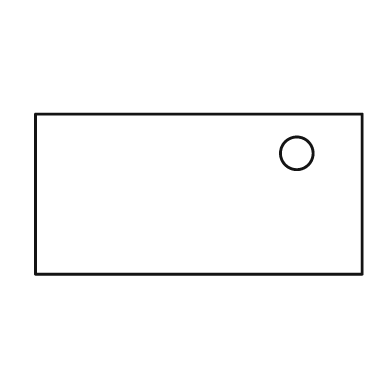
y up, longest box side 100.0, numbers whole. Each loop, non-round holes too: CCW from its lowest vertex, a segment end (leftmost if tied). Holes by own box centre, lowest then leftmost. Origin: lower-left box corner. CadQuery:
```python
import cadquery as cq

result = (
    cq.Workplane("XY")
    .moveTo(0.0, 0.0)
    .lineTo(100.0, 0.0)
    .lineTo(100.0, 49.0)
    .lineTo(0.0, 49.0)
    .close()
    .moveTo(80.0, 37.0)
    .circle(5.0)
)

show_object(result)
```